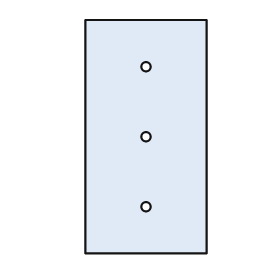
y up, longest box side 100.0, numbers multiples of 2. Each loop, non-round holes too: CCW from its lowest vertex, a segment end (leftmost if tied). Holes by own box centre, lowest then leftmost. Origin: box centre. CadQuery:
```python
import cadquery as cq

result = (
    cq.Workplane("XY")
    .moveTo(-26.0, -50.0)
    .lineTo(26.0, -50.0)
    .lineTo(26.0, 50.0)
    .lineTo(-26.0, 50.0)
    .close()
    .moveTo(0.0, -30.0)
    .circle(2.0)
    .moveTo(0.0, 0.0)
    .circle(2.0)
    .moveTo(0.0, 30.0)
    .circle(2.0)
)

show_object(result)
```